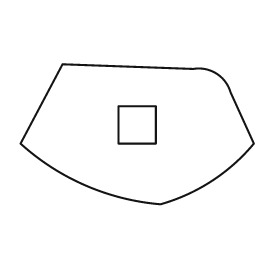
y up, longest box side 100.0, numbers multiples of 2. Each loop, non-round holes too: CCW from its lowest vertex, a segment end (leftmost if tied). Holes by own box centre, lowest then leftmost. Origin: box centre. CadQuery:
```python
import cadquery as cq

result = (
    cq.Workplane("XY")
    .moveTo(10.0, -30.0)
    .threePointArc((32.0, -20.0), (50.0, -4.0))
    .lineTo(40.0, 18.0)
    .threePointArc((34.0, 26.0), (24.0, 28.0))
    .lineTo(-32.0, 30.0)
    .lineTo(-50.0, -4.0)
    .threePointArc((-22.0, -22.0), (10.0, -30.0))
    .close()
    .moveTo(-8.0, -4.0)
    .lineTo(8.0, -4.0)
    .lineTo(8.0, 12.0)
    .lineTo(-8.0, 12.0)
    .close()
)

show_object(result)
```